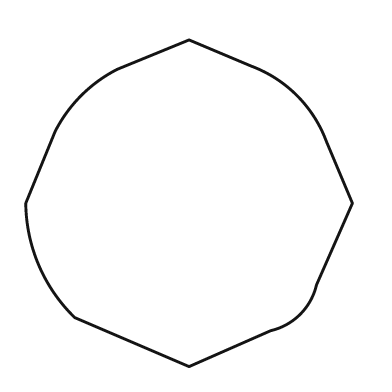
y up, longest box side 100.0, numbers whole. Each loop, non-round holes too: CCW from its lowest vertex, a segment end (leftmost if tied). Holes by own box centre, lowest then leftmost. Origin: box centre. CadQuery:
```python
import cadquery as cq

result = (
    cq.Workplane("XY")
    .moveTo(0.0, -50.0)
    .lineTo(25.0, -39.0)
    .threePointArc((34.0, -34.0), (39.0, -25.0))
    .lineTo(50.0, 0.0)
    .lineTo(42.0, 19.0)
    .threePointArc((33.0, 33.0), (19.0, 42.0))
    .lineTo(0.0, 50.0)
    .lineTo(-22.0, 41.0)
    .threePointArc((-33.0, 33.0), (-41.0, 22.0))
    .lineTo(-50.0, 0.0)
    .threePointArc((-46.0, -19.0), (-35.0, -35.0))
    .close()
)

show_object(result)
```